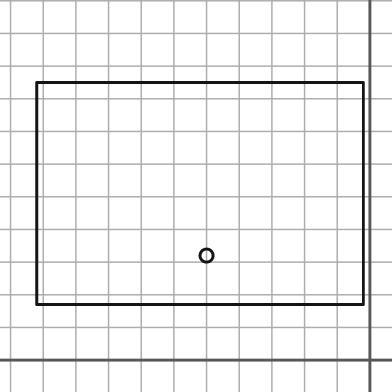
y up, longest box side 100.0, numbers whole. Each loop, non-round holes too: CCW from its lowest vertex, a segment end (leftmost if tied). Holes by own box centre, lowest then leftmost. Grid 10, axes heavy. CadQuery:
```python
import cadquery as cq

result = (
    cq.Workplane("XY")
    .moveTo(-102.0, 17.0)
    .lineTo(-2.0, 17.0)
    .lineTo(-2.0, 85.0)
    .lineTo(-102.0, 85.0)
    .close()
    .moveTo(-50.0, 32.0)
    .circle(2.0)
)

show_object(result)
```